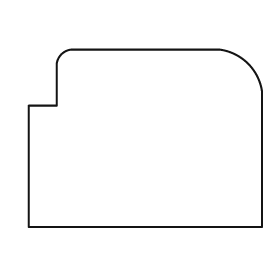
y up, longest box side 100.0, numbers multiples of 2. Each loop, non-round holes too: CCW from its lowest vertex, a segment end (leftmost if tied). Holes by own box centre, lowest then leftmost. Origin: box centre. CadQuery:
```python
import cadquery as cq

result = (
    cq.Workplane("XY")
    .moveTo(-50.0, -38.0)
    .lineTo(50.0, -38.0)
    .lineTo(50.0, 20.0)
    .threePointArc((44.0, 32.0), (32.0, 38.0))
    .lineTo(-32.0, 38.0)
    .threePointArc((-36.0, 36.0), (-38.0, 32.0))
    .lineTo(-38.0, 14.0)
    .lineTo(-50.0, 14.0)
    .close()
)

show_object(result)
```